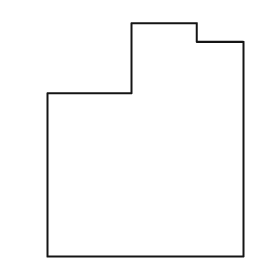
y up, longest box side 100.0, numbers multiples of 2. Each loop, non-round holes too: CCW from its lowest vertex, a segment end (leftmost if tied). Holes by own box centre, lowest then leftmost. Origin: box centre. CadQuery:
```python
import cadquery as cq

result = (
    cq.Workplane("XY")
    .moveTo(-42.0, -50.0)
    .lineTo(42.0, -50.0)
    .lineTo(42.0, 42.0)
    .lineTo(22.0, 42.0)
    .lineTo(22.0, 50.0)
    .lineTo(-6.0, 50.0)
    .lineTo(-6.0, 20.0)
    .lineTo(-42.0, 20.0)
    .close()
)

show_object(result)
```